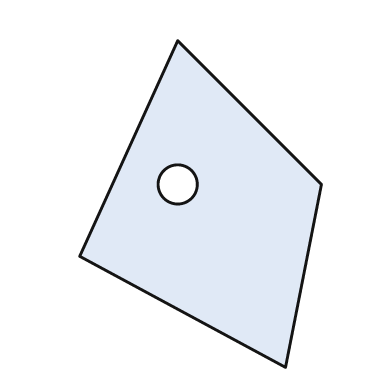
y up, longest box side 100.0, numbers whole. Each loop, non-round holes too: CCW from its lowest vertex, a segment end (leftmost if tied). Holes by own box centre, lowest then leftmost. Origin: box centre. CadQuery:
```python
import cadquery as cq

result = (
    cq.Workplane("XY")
    .moveTo(26.0, -50.0)
    .lineTo(37.0, 6.0)
    .lineTo(-7.0, 50.0)
    .lineTo(-37.0, -16.0)
    .close()
    .moveTo(-7.0, 6.0)
    .circle(6.0)
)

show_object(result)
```